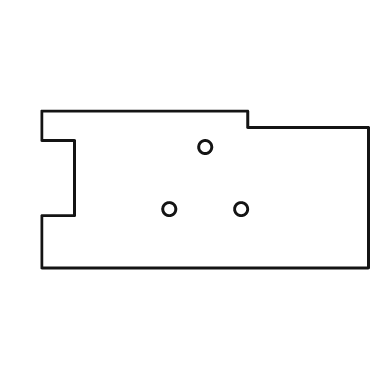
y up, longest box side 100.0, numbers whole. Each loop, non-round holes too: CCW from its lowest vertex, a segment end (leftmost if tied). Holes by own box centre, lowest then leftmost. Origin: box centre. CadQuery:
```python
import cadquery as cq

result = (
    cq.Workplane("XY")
    .moveTo(-50.0, -24.0)
    .lineTo(50.0, -24.0)
    .lineTo(50.0, 19.0)
    .lineTo(13.0, 19.0)
    .lineTo(13.0, 24.0)
    .lineTo(-50.0, 24.0)
    .lineTo(-50.0, 15.0)
    .lineTo(-40.0, 15.0)
    .lineTo(-40.0, -8.0)
    .lineTo(-50.0, -8.0)
    .close()
    .moveTo(-11.0, -6.0)
    .circle(2.0)
    .moveTo(11.0, -6.0)
    .circle(2.0)
    .moveTo(0.0, 13.0)
    .circle(2.0)
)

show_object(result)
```